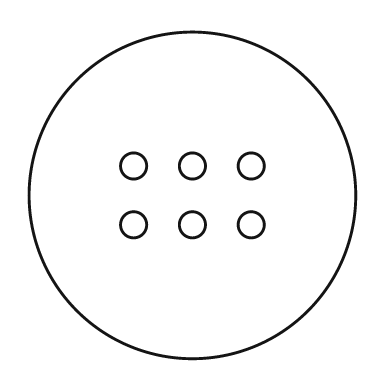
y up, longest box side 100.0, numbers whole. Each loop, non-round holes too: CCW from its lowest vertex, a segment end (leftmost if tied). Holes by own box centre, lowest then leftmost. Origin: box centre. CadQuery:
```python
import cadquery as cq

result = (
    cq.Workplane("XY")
    .moveTo(0.0, 0.0)
    .circle(50.0)
    .moveTo(-18.0, -9.0)
    .circle(4.0)
    .moveTo(0.0, -9.0)
    .circle(4.0)
    .moveTo(18.0, -9.0)
    .circle(4.0)
    .moveTo(-18.0, 9.0)
    .circle(4.0)
    .moveTo(0.0, 9.0)
    .circle(4.0)
    .moveTo(18.0, 9.0)
    .circle(4.0)
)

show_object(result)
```